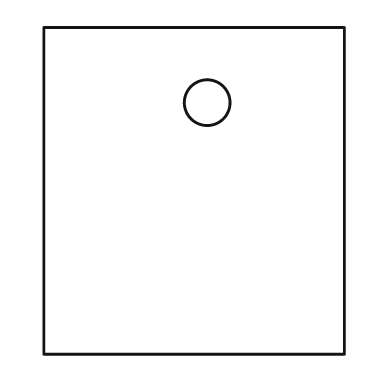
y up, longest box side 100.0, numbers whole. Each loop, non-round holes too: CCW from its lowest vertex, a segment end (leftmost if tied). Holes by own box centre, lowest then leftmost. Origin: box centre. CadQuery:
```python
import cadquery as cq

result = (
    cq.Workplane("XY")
    .moveTo(-46.0, -50.0)
    .lineTo(46.0, -50.0)
    .lineTo(46.0, 50.0)
    .lineTo(-46.0, 50.0)
    .close()
    .moveTo(4.0, 27.0)
    .circle(7.0)
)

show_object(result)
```